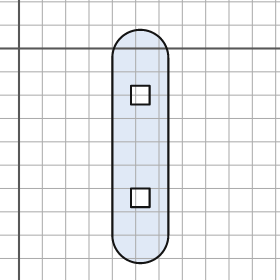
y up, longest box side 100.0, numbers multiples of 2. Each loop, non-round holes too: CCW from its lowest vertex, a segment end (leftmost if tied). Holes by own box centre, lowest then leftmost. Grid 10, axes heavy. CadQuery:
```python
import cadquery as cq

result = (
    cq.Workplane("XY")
    .moveTo(40.0, -80.0)
    .threePointArc((52.0, -92.0), (64.0, -80.0))
    .lineTo(64.0, -4.0)
    .threePointArc((52.0, 8.0), (40.0, -4.0))
    .close()
    .moveTo(48.0, -68.0)
    .lineTo(56.0, -68.0)
    .lineTo(56.0, -60.0)
    .lineTo(48.0, -60.0)
    .close()
    .moveTo(48.0, -24.0)
    .lineTo(56.0, -24.0)
    .lineTo(56.0, -16.0)
    .lineTo(48.0, -16.0)
    .close()
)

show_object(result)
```